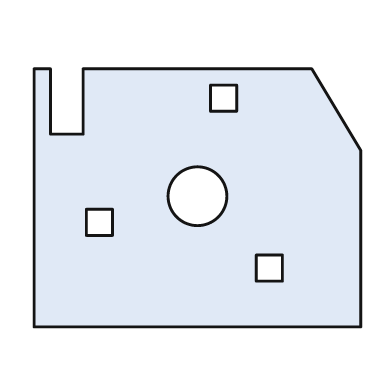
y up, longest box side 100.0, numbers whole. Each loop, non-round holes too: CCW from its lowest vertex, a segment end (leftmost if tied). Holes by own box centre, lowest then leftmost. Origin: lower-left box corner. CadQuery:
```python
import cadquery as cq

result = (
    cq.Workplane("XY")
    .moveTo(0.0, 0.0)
    .lineTo(100.0, 0.0)
    .lineTo(100.0, 54.0)
    .lineTo(85.0, 79.0)
    .lineTo(15.0, 79.0)
    .lineTo(15.0, 59.0)
    .lineTo(5.0, 59.0)
    .lineTo(5.0, 79.0)
    .lineTo(0.0, 79.0)
    .close()
    .moveTo(68.0, 14.0)
    .lineTo(76.0, 14.0)
    .lineTo(76.0, 22.0)
    .lineTo(68.0, 22.0)
    .close()
    .moveTo(16.0, 28.0)
    .lineTo(24.0, 28.0)
    .lineTo(24.0, 36.0)
    .lineTo(16.0, 36.0)
    .close()
    .moveTo(50.0, 40.0)
    .circle(9.0)
    .moveTo(54.0, 66.0)
    .lineTo(62.0, 66.0)
    .lineTo(62.0, 74.0)
    .lineTo(54.0, 74.0)
    .close()
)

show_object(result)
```